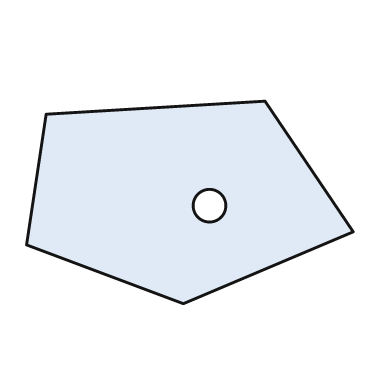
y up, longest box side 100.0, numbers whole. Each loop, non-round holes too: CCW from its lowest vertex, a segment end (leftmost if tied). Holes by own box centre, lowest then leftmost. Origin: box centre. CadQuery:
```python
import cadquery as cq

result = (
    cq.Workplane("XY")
    .moveTo(-2.0, -31.0)
    .lineTo(50.0, -9.0)
    .lineTo(23.0, 31.0)
    .lineTo(-44.0, 27.0)
    .lineTo(-50.0, -13.0)
    .close()
    .moveTo(6.0, -1.0)
    .circle(5.0)
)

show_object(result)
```